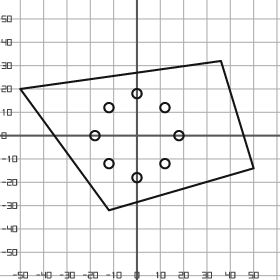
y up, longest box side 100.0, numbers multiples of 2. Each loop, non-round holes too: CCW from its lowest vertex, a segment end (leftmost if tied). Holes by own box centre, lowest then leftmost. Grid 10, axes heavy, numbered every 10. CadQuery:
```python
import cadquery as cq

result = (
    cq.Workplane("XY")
    .moveTo(-12.0, -32.0)
    .lineTo(50.0, -14.0)
    .lineTo(36.0, 32.0)
    .lineTo(-50.0, 20.0)
    .close()
    .moveTo(0.0, -18.0)
    .circle(2.0)
    .moveTo(-12.0, -12.0)
    .circle(2.0)
    .moveTo(12.0, -12.0)
    .circle(2.0)
    .moveTo(-18.0, 0.0)
    .circle(2.0)
    .moveTo(18.0, 0.0)
    .circle(2.0)
    .moveTo(-12.0, 12.0)
    .circle(2.0)
    .moveTo(12.0, 12.0)
    .circle(2.0)
    .moveTo(0.0, 18.0)
    .circle(2.0)
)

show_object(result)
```